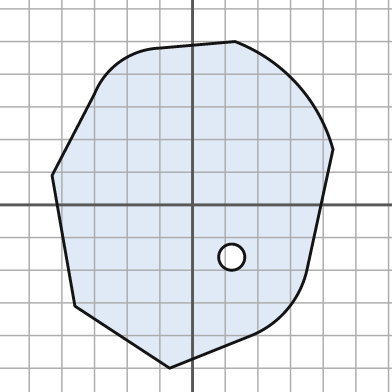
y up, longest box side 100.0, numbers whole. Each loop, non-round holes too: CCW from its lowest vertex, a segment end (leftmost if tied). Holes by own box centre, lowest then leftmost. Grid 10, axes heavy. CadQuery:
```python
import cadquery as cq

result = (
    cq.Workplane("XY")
    .moveTo(-7.0, -50.0)
    .lineTo(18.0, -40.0)
    .threePointArc((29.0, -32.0), (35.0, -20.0))
    .lineTo(43.0, 17.0)
    .threePointArc((32.0, 37.0), (13.0, 50.0))
    .lineTo(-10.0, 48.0)
    .threePointArc((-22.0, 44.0), (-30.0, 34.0))
    .lineTo(-43.0, 9.0)
    .lineTo(-36.0, -31.0)
    .close()
    .moveTo(12.0, -16.0)
    .circle(4.0)
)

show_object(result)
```